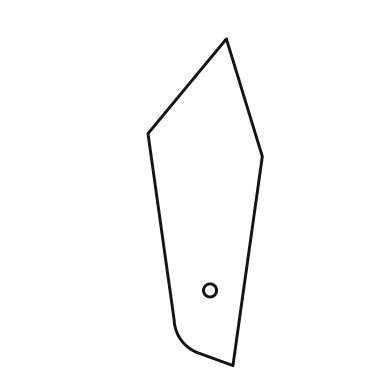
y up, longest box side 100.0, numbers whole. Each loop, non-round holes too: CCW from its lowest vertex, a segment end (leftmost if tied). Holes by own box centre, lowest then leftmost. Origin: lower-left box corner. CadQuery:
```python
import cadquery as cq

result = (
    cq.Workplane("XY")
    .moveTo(26.0, 0.0)
    .lineTo(35.0, 64.0)
    .lineTo(24.0, 100.0)
    .lineTo(0.0, 71.0)
    .lineTo(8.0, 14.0)
    .threePointArc((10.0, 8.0), (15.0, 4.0))
    .close()
    .moveTo(19.0, 23.0)
    .circle(2.0)
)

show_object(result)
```